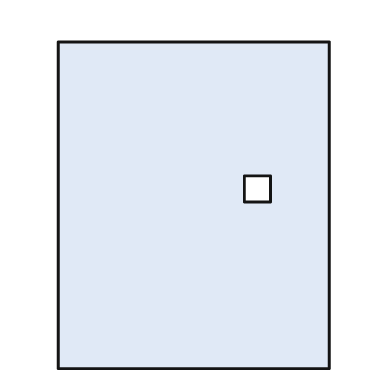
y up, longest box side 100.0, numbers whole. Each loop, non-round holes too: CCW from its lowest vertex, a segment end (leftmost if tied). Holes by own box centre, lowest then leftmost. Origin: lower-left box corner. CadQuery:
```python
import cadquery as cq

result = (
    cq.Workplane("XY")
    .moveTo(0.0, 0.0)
    .lineTo(83.0, 0.0)
    .lineTo(83.0, 100.0)
    .lineTo(0.0, 100.0)
    .close()
    .moveTo(57.0, 51.0)
    .lineTo(65.0, 51.0)
    .lineTo(65.0, 59.0)
    .lineTo(57.0, 59.0)
    .close()
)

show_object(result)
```